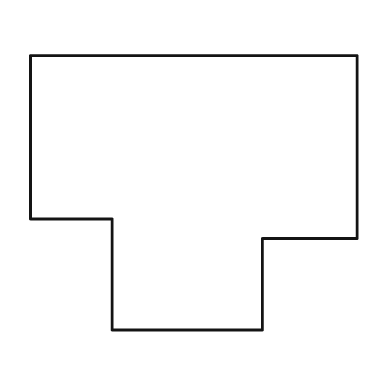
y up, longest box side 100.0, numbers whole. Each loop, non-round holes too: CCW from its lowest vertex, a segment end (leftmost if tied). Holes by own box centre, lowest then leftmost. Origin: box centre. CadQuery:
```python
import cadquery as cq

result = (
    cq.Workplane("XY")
    .moveTo(-25.0, -42.0)
    .lineTo(21.0, -42.0)
    .lineTo(21.0, -14.0)
    .lineTo(50.0, -14.0)
    .lineTo(50.0, 42.0)
    .lineTo(-50.0, 42.0)
    .lineTo(-50.0, -8.0)
    .lineTo(-25.0, -8.0)
    .close()
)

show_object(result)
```